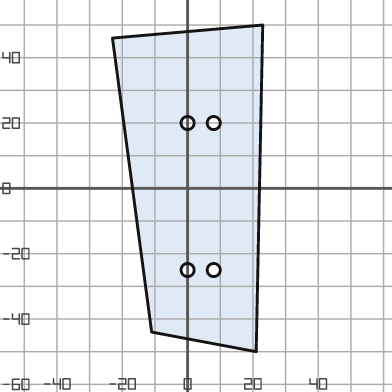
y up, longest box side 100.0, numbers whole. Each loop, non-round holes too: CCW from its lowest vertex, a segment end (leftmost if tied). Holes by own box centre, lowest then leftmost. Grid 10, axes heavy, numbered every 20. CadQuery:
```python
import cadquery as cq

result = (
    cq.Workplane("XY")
    .moveTo(21.0, -50.0)
    .lineTo(23.0, 50.0)
    .lineTo(-23.0, 46.0)
    .lineTo(-11.0, -44.0)
    .close()
    .moveTo(0.0, -25.0)
    .circle(2.0)
    .moveTo(8.0, -25.0)
    .circle(2.0)
    .moveTo(0.0, 20.0)
    .circle(2.0)
    .moveTo(8.0, 20.0)
    .circle(2.0)
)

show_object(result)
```